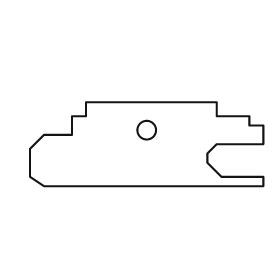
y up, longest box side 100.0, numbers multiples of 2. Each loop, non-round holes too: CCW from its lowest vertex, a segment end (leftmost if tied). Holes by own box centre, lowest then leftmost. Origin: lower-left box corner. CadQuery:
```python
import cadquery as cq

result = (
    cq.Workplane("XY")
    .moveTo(6.0, 0.0)
    .lineTo(100.0, 0.0)
    .lineTo(100.0, 4.0)
    .lineTo(82.0, 4.0)
    .lineTo(76.0, 10.0)
    .lineTo(76.0, 14.0)
    .lineTo(80.0, 18.0)
    .lineTo(100.0, 18.0)
    .lineTo(100.0, 26.0)
    .lineTo(94.0, 26.0)
    .lineTo(94.0, 30.0)
    .lineTo(80.0, 30.0)
    .lineTo(80.0, 36.0)
    .lineTo(24.0, 36.0)
    .lineTo(24.0, 30.0)
    .lineTo(18.0, 30.0)
    .lineTo(18.0, 22.0)
    .lineTo(6.0, 22.0)
    .lineTo(0.0, 16.0)
    .lineTo(0.0, 4.0)
    .close()
    .moveTo(50.0, 24.0)
    .circle(4.0)
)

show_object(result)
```